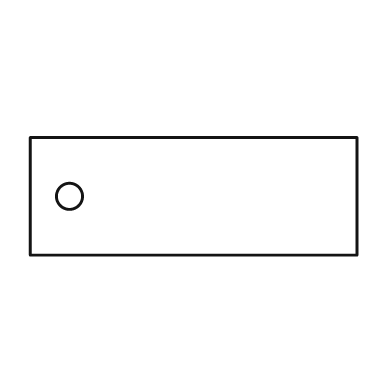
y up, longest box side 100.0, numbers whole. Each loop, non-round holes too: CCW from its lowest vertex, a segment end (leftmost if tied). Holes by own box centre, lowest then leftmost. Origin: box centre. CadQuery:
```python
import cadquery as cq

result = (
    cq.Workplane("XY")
    .moveTo(-50.0, -18.0)
    .lineTo(50.0, -18.0)
    .lineTo(50.0, 18.0)
    .lineTo(-50.0, 18.0)
    .close()
    .moveTo(-38.0, 0.0)
    .circle(4.0)
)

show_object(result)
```